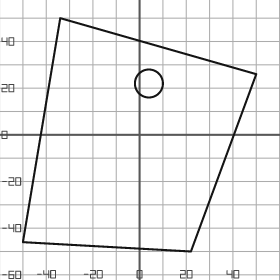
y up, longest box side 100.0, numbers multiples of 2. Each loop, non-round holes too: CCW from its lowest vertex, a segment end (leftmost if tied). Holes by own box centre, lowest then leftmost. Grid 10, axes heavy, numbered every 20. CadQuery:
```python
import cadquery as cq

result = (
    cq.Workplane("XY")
    .moveTo(22.0, -50.0)
    .lineTo(50.0, 26.0)
    .lineTo(-34.0, 50.0)
    .lineTo(-50.0, -46.0)
    .close()
    .moveTo(4.0, 22.0)
    .circle(6.0)
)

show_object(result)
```